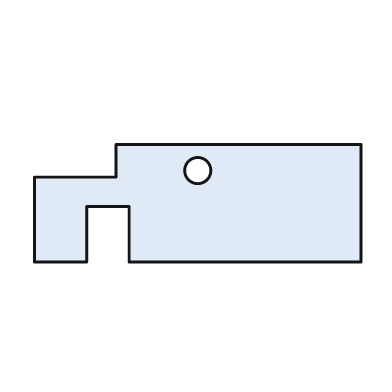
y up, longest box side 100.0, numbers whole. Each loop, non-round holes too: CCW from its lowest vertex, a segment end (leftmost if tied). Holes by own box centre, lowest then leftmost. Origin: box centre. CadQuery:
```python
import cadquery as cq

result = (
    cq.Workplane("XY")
    .moveTo(-50.0, -18.0)
    .lineTo(-34.0, -18.0)
    .lineTo(-34.0, -1.0)
    .lineTo(-21.0, -1.0)
    .lineTo(-21.0, -18.0)
    .lineTo(50.0, -18.0)
    .lineTo(50.0, 18.0)
    .lineTo(-25.0, 18.0)
    .lineTo(-25.0, 8.0)
    .lineTo(-50.0, 8.0)
    .close()
    .moveTo(0.0, 10.0)
    .circle(4.0)
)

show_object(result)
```